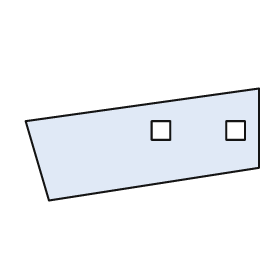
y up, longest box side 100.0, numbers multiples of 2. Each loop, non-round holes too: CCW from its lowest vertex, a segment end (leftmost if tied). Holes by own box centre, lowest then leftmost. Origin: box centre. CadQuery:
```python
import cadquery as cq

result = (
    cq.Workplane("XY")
    .moveTo(-40.0, -24.0)
    .lineTo(50.0, -10.0)
    .lineTo(50.0, 24.0)
    .lineTo(-50.0, 10.0)
    .close()
    .moveTo(4.0, 2.0)
    .lineTo(12.0, 2.0)
    .lineTo(12.0, 10.0)
    .lineTo(4.0, 10.0)
    .close()
    .moveTo(36.0, 2.0)
    .lineTo(44.0, 2.0)
    .lineTo(44.0, 10.0)
    .lineTo(36.0, 10.0)
    .close()
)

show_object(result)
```